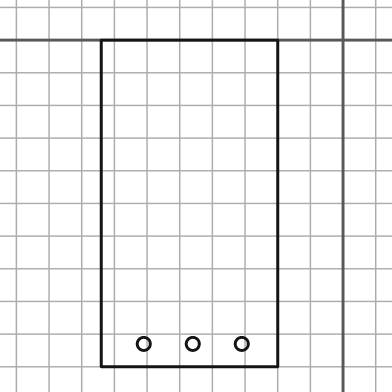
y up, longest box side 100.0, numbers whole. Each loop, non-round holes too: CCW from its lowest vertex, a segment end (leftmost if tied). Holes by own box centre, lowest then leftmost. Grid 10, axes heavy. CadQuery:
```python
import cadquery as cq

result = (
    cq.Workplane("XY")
    .moveTo(-74.0, -100.0)
    .lineTo(-20.0, -100.0)
    .lineTo(-20.0, 0.0)
    .lineTo(-74.0, 0.0)
    .close()
    .moveTo(-61.0, -93.0)
    .circle(2.0)
    .moveTo(-46.0, -93.0)
    .circle(2.0)
    .moveTo(-31.0, -93.0)
    .circle(2.0)
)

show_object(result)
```